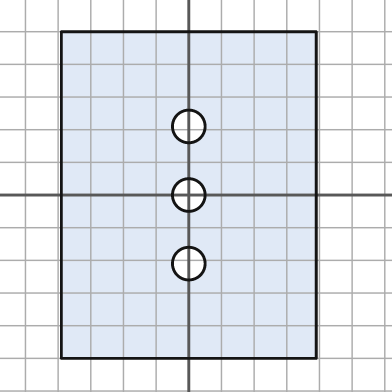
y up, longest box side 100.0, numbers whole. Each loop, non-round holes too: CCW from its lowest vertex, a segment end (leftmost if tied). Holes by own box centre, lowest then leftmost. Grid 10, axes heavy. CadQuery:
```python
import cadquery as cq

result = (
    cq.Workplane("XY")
    .moveTo(-39.0, -50.0)
    .lineTo(39.0, -50.0)
    .lineTo(39.0, 50.0)
    .lineTo(-39.0, 50.0)
    .close()
    .moveTo(0.0, -21.0)
    .circle(5.0)
    .moveTo(0.0, 0.0)
    .circle(5.0)
    .moveTo(0.0, 21.0)
    .circle(5.0)
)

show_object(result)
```